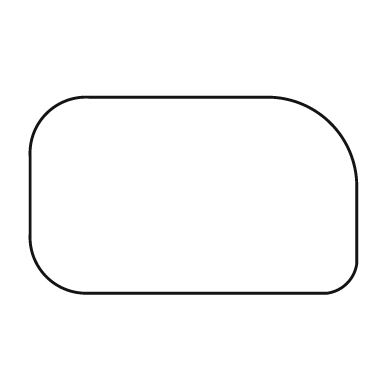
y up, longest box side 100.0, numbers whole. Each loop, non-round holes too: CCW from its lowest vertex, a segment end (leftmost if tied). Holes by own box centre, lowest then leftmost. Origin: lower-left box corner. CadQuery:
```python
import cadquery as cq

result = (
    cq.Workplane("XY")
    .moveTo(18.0, 0.0)
    .lineTo(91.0, 0.0)
    .threePointArc((97.0, 3.0), (100.0, 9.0))
    .lineTo(100.0, 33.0)
    .threePointArc((92.0, 52.0), (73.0, 60.0))
    .lineTo(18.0, 60.0)
    .threePointArc((5.0, 55.0), (0.0, 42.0))
    .lineTo(0.0, 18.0)
    .threePointArc((5.0, 5.0), (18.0, 0.0))
    .close()
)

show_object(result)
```